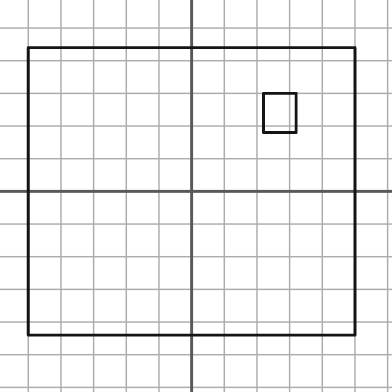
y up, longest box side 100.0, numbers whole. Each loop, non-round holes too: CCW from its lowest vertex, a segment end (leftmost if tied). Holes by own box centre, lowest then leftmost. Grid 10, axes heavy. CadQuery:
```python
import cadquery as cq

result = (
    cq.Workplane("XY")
    .moveTo(-50.0, -44.0)
    .lineTo(50.0, -44.0)
    .lineTo(50.0, 44.0)
    .lineTo(-50.0, 44.0)
    .close()
    .moveTo(22.0, 18.0)
    .lineTo(32.0, 18.0)
    .lineTo(32.0, 30.0)
    .lineTo(22.0, 30.0)
    .close()
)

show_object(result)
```